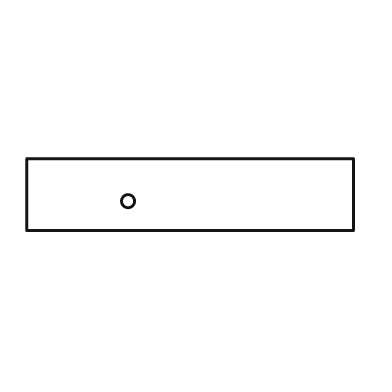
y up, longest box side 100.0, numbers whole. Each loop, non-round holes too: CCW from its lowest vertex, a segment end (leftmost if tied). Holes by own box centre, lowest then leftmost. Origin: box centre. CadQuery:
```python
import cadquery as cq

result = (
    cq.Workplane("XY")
    .moveTo(-50.0, -11.0)
    .lineTo(50.0, -11.0)
    .lineTo(50.0, 11.0)
    .lineTo(-50.0, 11.0)
    .close()
    .moveTo(-19.0, -2.0)
    .circle(2.0)
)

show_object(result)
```